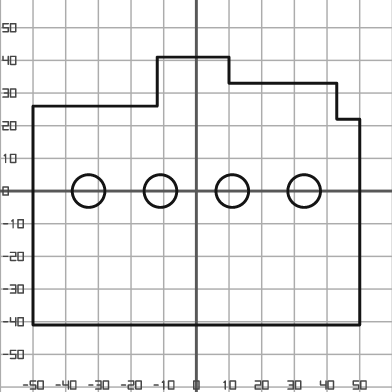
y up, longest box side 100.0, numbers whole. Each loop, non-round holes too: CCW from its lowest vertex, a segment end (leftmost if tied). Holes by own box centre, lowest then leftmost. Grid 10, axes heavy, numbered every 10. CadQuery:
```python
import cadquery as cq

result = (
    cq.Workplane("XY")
    .moveTo(-50.0, -41.0)
    .lineTo(50.0, -41.0)
    .lineTo(50.0, 22.0)
    .lineTo(43.0, 22.0)
    .lineTo(43.0, 33.0)
    .lineTo(10.0, 33.0)
    .lineTo(10.0, 41.0)
    .lineTo(-12.0, 41.0)
    .lineTo(-12.0, 26.0)
    .lineTo(-50.0, 26.0)
    .close()
    .moveTo(-33.0, 0.0)
    .circle(5.0)
    .moveTo(-11.0, 0.0)
    .circle(5.0)
    .moveTo(11.0, 0.0)
    .circle(5.0)
    .moveTo(33.0, 0.0)
    .circle(5.0)
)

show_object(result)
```